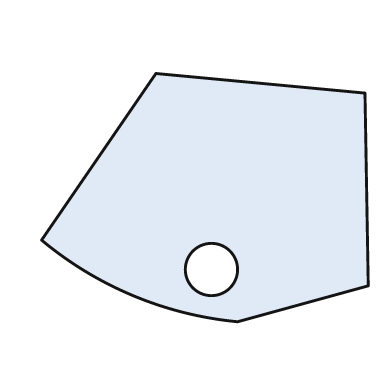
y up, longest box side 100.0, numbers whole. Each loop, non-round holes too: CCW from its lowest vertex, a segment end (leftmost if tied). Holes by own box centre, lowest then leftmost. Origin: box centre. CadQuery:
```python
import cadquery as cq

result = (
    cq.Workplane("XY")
    .moveTo(10.0, -38.0)
    .lineTo(50.0, -27.0)
    .lineTo(49.0, 32.0)
    .lineTo(-15.0, 38.0)
    .lineTo(-50.0, -13.0)
    .threePointArc((-22.0, -30.0), (10.0, -38.0))
    .close()
    .moveTo(2.0, -22.0)
    .circle(8.0)
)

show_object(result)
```